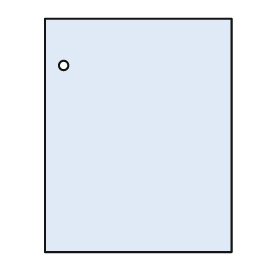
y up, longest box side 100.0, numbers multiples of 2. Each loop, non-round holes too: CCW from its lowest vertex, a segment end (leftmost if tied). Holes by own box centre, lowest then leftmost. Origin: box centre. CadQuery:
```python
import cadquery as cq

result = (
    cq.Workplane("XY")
    .moveTo(-40.0, -50.0)
    .lineTo(40.0, -50.0)
    .lineTo(40.0, 50.0)
    .lineTo(-40.0, 50.0)
    .close()
    .moveTo(-32.0, 30.0)
    .circle(2.0)
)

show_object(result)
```